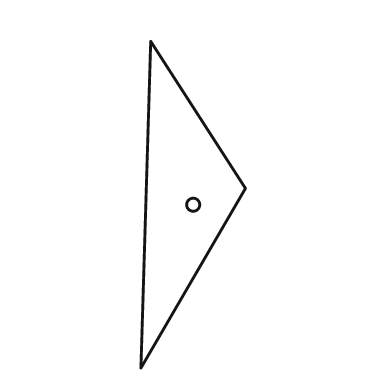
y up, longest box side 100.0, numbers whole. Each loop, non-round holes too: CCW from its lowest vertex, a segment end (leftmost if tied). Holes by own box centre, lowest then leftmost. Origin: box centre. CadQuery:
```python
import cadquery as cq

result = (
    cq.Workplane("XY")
    .moveTo(-16.0, -50.0)
    .lineTo(16.0, 5.0)
    .lineTo(-13.0, 50.0)
    .close()
    .moveTo(0.0, 0.0)
    .circle(2.0)
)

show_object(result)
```